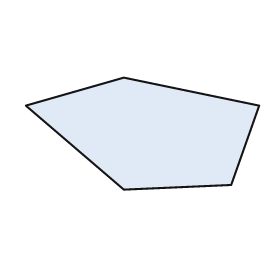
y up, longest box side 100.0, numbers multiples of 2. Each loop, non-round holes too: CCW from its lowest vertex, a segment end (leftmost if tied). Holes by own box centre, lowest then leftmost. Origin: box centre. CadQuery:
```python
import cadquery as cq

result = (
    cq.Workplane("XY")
    .moveTo(-8.0, -24.0)
    .lineTo(38.0, -22.0)
    .lineTo(50.0, 12.0)
    .lineTo(-8.0, 24.0)
    .lineTo(-50.0, 12.0)
    .close()
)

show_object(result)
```